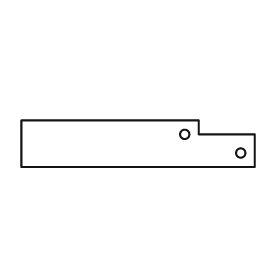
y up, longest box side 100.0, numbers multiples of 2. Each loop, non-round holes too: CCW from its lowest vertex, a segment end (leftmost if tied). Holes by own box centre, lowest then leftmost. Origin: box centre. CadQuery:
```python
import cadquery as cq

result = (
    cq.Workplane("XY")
    .moveTo(-50.0, -10.0)
    .lineTo(50.0, -10.0)
    .lineTo(50.0, 4.0)
    .lineTo(26.0, 4.0)
    .lineTo(26.0, 10.0)
    .lineTo(-50.0, 10.0)
    .close()
    .moveTo(44.0, -4.0)
    .circle(2.0)
    .moveTo(20.0, 4.0)
    .circle(2.0)
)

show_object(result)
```